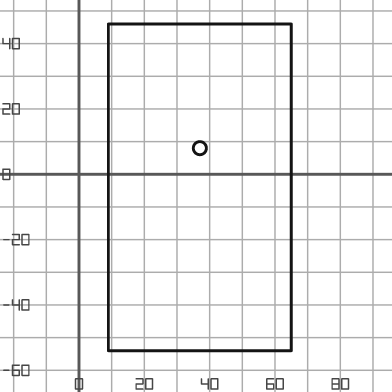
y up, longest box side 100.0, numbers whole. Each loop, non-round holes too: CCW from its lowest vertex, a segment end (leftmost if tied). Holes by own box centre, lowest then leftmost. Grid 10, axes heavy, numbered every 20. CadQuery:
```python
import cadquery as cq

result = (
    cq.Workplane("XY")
    .moveTo(9.0, -54.0)
    .lineTo(65.0, -54.0)
    .lineTo(65.0, 46.0)
    .lineTo(9.0, 46.0)
    .close()
    .moveTo(37.0, 8.0)
    .circle(2.0)
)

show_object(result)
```